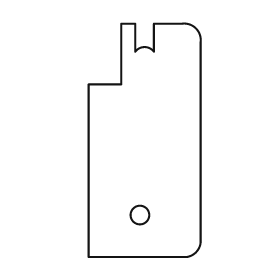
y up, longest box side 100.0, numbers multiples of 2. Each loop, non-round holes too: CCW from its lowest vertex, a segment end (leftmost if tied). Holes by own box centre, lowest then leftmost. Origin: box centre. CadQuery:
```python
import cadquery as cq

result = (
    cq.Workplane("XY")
    .moveTo(-24.0, -50.0)
    .lineTo(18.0, -50.0)
    .threePointArc((22.0, -48.0), (24.0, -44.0))
    .lineTo(24.0, 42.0)
    .threePointArc((22.0, 48.0), (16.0, 50.0))
    .lineTo(4.0, 50.0)
    .lineTo(4.0, 38.0)
    .threePointArc((0.0, 40.0), (-4.0, 38.0))
    .lineTo(-4.0, 50.0)
    .lineTo(-10.0, 50.0)
    .lineTo(-10.0, 24.0)
    .lineTo(-24.0, 24.0)
    .close()
    .moveTo(-2.0, -32.0)
    .circle(4.0)
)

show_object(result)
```